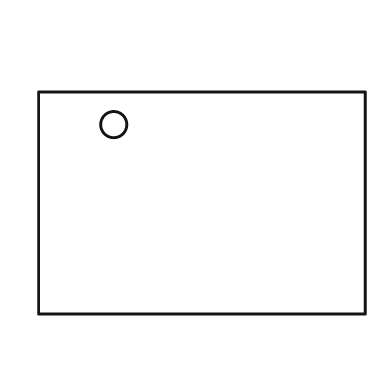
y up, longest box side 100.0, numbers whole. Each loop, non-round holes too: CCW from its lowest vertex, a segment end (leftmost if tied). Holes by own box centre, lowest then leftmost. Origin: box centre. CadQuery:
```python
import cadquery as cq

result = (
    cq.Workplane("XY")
    .moveTo(-50.0, -34.0)
    .lineTo(50.0, -34.0)
    .lineTo(50.0, 34.0)
    .lineTo(-50.0, 34.0)
    .close()
    .moveTo(-27.0, 24.0)
    .circle(4.0)
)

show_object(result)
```